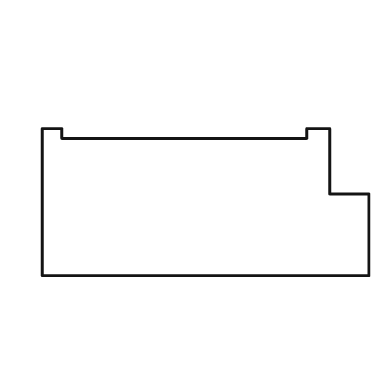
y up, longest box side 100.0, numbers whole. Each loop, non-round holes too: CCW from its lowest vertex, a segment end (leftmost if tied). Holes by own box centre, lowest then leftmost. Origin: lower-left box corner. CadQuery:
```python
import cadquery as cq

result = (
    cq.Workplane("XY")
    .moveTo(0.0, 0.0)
    .lineTo(100.0, 0.0)
    .lineTo(100.0, 25.0)
    .lineTo(88.0, 25.0)
    .lineTo(88.0, 45.0)
    .lineTo(81.0, 45.0)
    .lineTo(81.0, 42.0)
    .lineTo(6.0, 42.0)
    .lineTo(6.0, 45.0)
    .lineTo(0.0, 45.0)
    .close()
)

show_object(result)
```